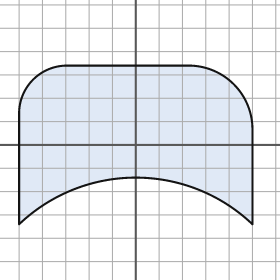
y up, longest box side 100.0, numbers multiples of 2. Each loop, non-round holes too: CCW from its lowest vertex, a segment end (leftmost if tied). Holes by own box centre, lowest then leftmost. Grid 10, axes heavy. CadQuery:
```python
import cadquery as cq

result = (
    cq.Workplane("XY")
    .moveTo(-50.0, -34.0)
    .threePointArc((0.0, -14.0), (50.0, -34.0))
    .lineTo(50.0, 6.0)
    .threePointArc((42.0, 26.0), (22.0, 34.0))
    .lineTo(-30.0, 34.0)
    .threePointArc((-44.0, 28.0), (-50.0, 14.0))
    .close()
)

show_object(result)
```